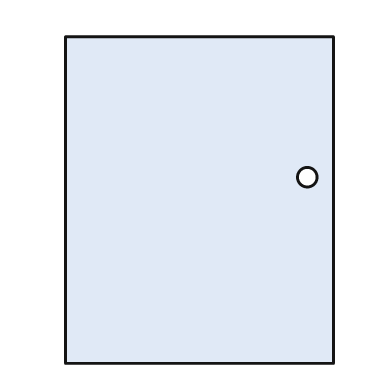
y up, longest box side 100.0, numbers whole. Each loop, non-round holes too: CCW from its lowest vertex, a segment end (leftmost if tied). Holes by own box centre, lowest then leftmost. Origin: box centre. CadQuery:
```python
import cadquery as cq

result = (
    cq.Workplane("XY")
    .moveTo(-41.0, -50.0)
    .lineTo(41.0, -50.0)
    .lineTo(41.0, 50.0)
    .lineTo(-41.0, 50.0)
    .close()
    .moveTo(33.0, 7.0)
    .circle(3.0)
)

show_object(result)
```